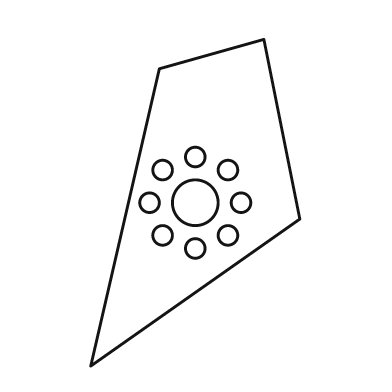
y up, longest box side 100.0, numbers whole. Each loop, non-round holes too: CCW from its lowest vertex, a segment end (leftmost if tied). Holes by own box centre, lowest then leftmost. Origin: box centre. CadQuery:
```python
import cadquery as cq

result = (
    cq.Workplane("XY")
    .moveTo(-32.0, -50.0)
    .lineTo(32.0, -5.0)
    .lineTo(21.0, 50.0)
    .lineTo(-11.0, 41.0)
    .close()
    .moveTo(0.0, -14.0)
    .circle(3.0)
    .moveTo(-10.0, -10.0)
    .circle(3.0)
    .moveTo(10.0, -10.0)
    .circle(3.0)
    .moveTo(-14.0, 0.0)
    .circle(3.0)
    .moveTo(0.0, 0.0)
    .circle(7.0)
    .moveTo(14.0, 0.0)
    .circle(3.0)
    .moveTo(-10.0, 10.0)
    .circle(3.0)
    .moveTo(10.0, 10.0)
    .circle(3.0)
    .moveTo(0.0, 14.0)
    .circle(3.0)
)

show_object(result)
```